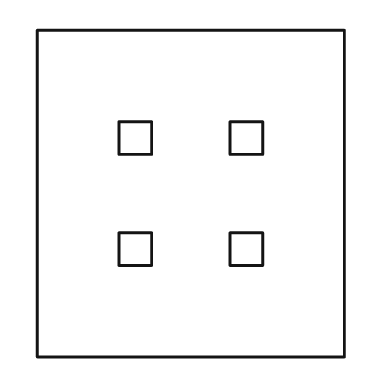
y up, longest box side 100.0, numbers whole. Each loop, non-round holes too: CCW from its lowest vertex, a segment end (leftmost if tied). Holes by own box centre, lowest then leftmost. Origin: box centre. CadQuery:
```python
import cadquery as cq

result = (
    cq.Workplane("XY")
    .moveTo(-47.0, -50.0)
    .lineTo(47.0, -50.0)
    .lineTo(47.0, 50.0)
    .lineTo(-47.0, 50.0)
    .close()
    .moveTo(-22.0, -22.0)
    .lineTo(-12.0, -22.0)
    .lineTo(-12.0, -12.0)
    .lineTo(-22.0, -12.0)
    .close()
    .moveTo(12.0, -22.0)
    .lineTo(22.0, -22.0)
    .lineTo(22.0, -12.0)
    .lineTo(12.0, -12.0)
    .close()
    .moveTo(-22.0, 12.0)
    .lineTo(-12.0, 12.0)
    .lineTo(-12.0, 22.0)
    .lineTo(-22.0, 22.0)
    .close()
    .moveTo(12.0, 12.0)
    .lineTo(22.0, 12.0)
    .lineTo(22.0, 22.0)
    .lineTo(12.0, 22.0)
    .close()
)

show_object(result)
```